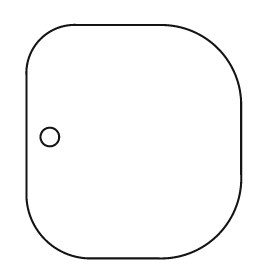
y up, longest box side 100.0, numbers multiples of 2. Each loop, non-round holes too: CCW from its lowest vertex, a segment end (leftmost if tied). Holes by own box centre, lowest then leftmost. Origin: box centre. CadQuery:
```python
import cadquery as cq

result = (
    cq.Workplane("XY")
    .moveTo(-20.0, -50.0)
    .lineTo(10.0, -50.0)
    .threePointArc((36.0, -40.0), (46.0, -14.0))
    .lineTo(46.0, 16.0)
    .threePointArc((36.0, 40.0), (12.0, 50.0))
    .lineTo(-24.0, 50.0)
    .threePointArc((-40.0, 44.0), (-46.0, 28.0))
    .lineTo(-46.0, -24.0)
    .threePointArc((-38.0, -42.0), (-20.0, -50.0))
    .close()
    .moveTo(-36.0, 2.0)
    .circle(4.0)
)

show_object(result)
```